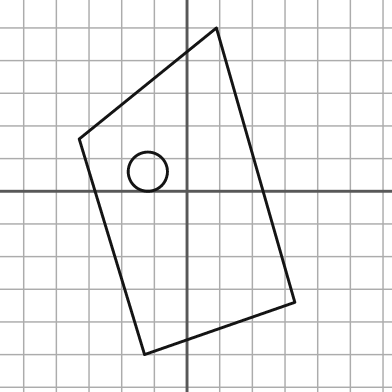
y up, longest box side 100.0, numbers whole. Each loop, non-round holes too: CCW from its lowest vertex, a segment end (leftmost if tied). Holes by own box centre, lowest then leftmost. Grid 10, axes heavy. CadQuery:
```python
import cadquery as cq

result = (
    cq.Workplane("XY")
    .moveTo(-13.0, -50.0)
    .lineTo(33.0, -34.0)
    .lineTo(9.0, 50.0)
    .lineTo(-33.0, 16.0)
    .close()
    .moveTo(-12.0, 6.0)
    .circle(6.0)
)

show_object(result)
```